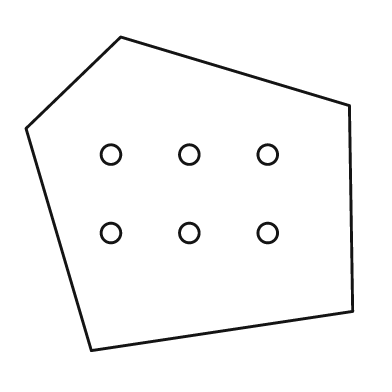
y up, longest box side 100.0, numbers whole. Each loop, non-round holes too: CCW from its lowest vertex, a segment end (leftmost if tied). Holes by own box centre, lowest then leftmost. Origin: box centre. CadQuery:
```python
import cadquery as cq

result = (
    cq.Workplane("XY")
    .moveTo(-30.0, -48.0)
    .lineTo(50.0, -36.0)
    .lineTo(49.0, 27.0)
    .lineTo(-21.0, 48.0)
    .lineTo(-50.0, 20.0)
    .close()
    .moveTo(-24.0, -12.0)
    .circle(3.0)
    .moveTo(0.0, -12.0)
    .circle(3.0)
    .moveTo(24.0, -12.0)
    .circle(3.0)
    .moveTo(-24.0, 12.0)
    .circle(3.0)
    .moveTo(0.0, 12.0)
    .circle(3.0)
    .moveTo(24.0, 12.0)
    .circle(3.0)
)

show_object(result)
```